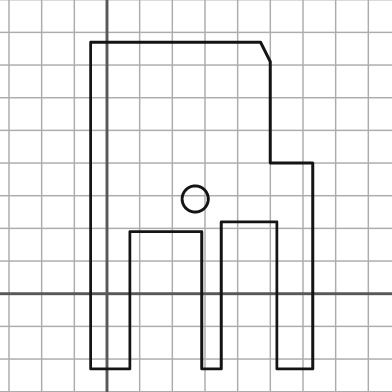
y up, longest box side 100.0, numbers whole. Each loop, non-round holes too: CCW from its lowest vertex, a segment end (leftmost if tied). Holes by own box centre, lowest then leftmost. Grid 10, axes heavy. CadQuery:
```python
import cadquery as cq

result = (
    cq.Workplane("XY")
    .moveTo(-5.0, -23.0)
    .lineTo(7.0, -23.0)
    .lineTo(7.0, 19.0)
    .lineTo(29.0, 19.0)
    .lineTo(29.0, -23.0)
    .lineTo(35.0, -23.0)
    .lineTo(35.0, 22.0)
    .lineTo(52.0, 22.0)
    .lineTo(52.0, -23.0)
    .lineTo(63.0, -23.0)
    .lineTo(63.0, 40.0)
    .lineTo(50.0, 40.0)
    .lineTo(50.0, 71.0)
    .lineTo(47.0, 77.0)
    .lineTo(-5.0, 77.0)
    .close()
    .moveTo(27.0, 29.0)
    .circle(4.0)
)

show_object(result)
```